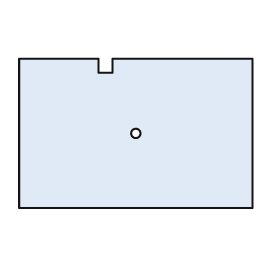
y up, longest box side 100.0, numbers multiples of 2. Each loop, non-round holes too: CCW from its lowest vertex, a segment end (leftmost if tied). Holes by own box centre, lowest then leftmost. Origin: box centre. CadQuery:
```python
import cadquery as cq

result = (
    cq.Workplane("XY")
    .moveTo(-50.0, -32.0)
    .lineTo(50.0, -32.0)
    .lineTo(50.0, 32.0)
    .lineTo(-10.0, 32.0)
    .lineTo(-10.0, 26.0)
    .lineTo(-16.0, 26.0)
    .lineTo(-16.0, 32.0)
    .lineTo(-50.0, 32.0)
    .close()
    .moveTo(0.0, 0.0)
    .circle(2.0)
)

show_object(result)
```